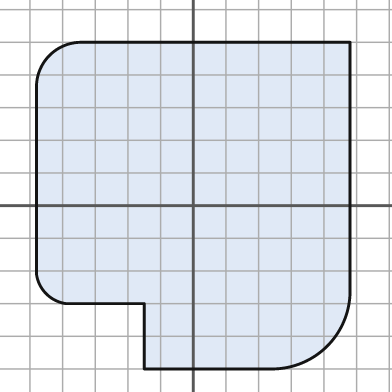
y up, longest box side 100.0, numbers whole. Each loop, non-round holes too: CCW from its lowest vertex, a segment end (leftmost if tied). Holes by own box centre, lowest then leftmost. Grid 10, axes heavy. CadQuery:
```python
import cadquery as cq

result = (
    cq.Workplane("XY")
    .moveTo(-15.0, -50.0)
    .lineTo(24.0, -50.0)
    .threePointArc((41.0, -43.0), (48.0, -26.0))
    .lineTo(48.0, 50.0)
    .lineTo(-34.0, 50.0)
    .threePointArc((-44.0, 46.0), (-48.0, 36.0))
    .lineTo(-48.0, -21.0)
    .threePointArc((-45.0, -27.0), (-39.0, -30.0))
    .lineTo(-15.0, -30.0)
    .close()
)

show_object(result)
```